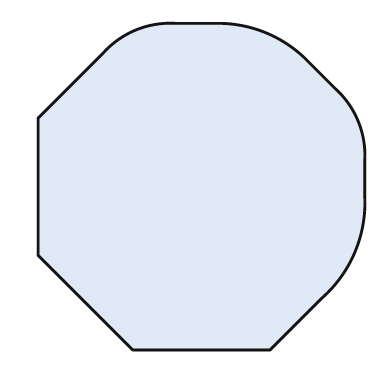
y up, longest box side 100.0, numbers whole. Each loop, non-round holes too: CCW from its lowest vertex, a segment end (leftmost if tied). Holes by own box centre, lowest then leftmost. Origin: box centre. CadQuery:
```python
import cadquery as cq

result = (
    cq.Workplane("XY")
    .moveTo(-21.0, -50.0)
    .lineTo(21.0, -50.0)
    .lineTo(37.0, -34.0)
    .threePointArc((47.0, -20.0), (50.0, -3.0))
    .lineTo(50.0, 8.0)
    .threePointArc((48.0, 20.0), (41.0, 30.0))
    .lineTo(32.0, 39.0)
    .threePointArc((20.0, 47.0), (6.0, 50.0))
    .lineTo(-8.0, 50.0)
    .threePointArc((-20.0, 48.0), (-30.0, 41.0))
    .lineTo(-50.0, 21.0)
    .lineTo(-50.0, -21.0)
    .close()
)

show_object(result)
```